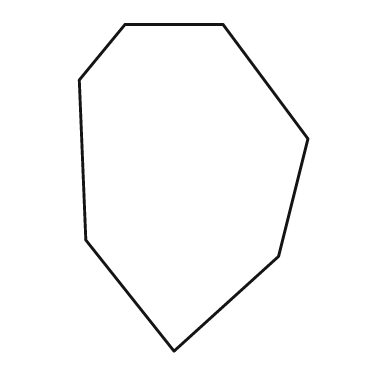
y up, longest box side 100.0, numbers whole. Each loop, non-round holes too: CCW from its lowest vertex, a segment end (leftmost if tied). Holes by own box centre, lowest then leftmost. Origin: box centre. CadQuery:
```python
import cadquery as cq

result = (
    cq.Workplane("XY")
    .moveTo(-6.0, -50.0)
    .lineTo(26.0, -21.0)
    .lineTo(35.0, 15.0)
    .lineTo(9.0, 50.0)
    .lineTo(-21.0, 50.0)
    .lineTo(-35.0, 33.0)
    .lineTo(-33.0, -16.0)
    .close()
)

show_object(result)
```